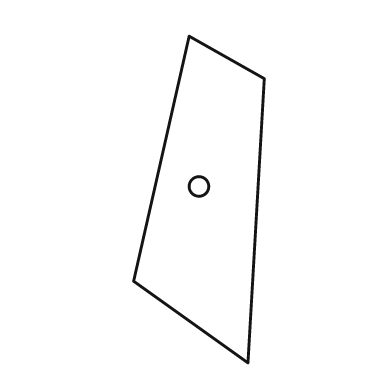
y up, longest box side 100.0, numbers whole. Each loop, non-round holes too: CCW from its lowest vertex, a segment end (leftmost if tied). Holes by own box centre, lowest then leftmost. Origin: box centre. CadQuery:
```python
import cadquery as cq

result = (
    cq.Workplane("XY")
    .moveTo(15.0, -50.0)
    .lineTo(20.0, 37.0)
    .lineTo(-3.0, 50.0)
    .lineTo(-20.0, -25.0)
    .close()
    .moveTo(0.0, 4.0)
    .circle(3.0)
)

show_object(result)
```